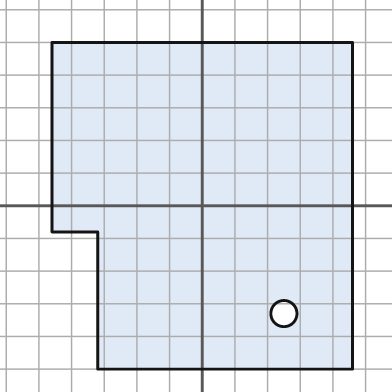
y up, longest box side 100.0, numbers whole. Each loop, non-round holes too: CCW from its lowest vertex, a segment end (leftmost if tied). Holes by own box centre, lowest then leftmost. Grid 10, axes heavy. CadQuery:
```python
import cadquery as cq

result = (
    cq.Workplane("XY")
    .moveTo(-32.0, -50.0)
    .lineTo(46.0, -50.0)
    .lineTo(46.0, 50.0)
    .lineTo(-46.0, 50.0)
    .lineTo(-46.0, -8.0)
    .lineTo(-32.0, -8.0)
    .close()
    .moveTo(25.0, -33.0)
    .circle(4.0)
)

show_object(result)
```